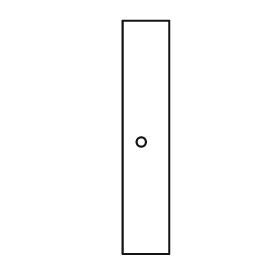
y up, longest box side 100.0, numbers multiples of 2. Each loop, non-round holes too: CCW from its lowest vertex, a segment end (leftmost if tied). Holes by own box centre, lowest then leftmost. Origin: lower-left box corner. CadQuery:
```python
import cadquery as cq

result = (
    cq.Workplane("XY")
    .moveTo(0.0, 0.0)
    .lineTo(20.0, 0.0)
    .lineTo(20.0, 100.0)
    .lineTo(0.0, 100.0)
    .close()
    .moveTo(8.0, 48.0)
    .circle(2.0)
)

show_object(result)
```